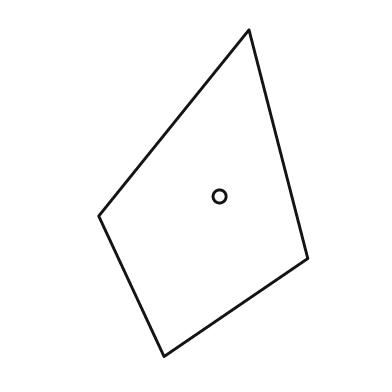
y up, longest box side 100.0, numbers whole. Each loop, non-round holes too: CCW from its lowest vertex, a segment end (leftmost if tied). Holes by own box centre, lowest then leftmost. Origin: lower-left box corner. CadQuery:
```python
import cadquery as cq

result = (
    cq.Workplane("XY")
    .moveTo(20.0, 0.0)
    .lineTo(64.0, 30.0)
    .lineTo(46.0, 100.0)
    .lineTo(0.0, 43.0)
    .close()
    .moveTo(37.0, 49.0)
    .circle(2.0)
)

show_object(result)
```